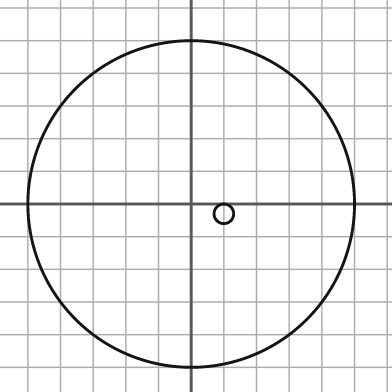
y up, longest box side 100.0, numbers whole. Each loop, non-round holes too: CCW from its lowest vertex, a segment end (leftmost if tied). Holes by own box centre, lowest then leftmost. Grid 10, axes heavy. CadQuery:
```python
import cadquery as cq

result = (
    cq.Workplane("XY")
    .moveTo(0.0, 0.0)
    .circle(50.0)
    .moveTo(10.0, -3.0)
    .circle(3.0)
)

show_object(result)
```